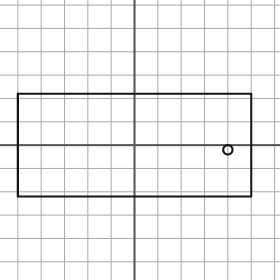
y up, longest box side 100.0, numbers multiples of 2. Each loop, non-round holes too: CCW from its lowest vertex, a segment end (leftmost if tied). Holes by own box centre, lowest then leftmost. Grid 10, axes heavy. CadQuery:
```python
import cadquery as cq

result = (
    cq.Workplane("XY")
    .moveTo(-50.0, -22.0)
    .lineTo(50.0, -22.0)
    .lineTo(50.0, 22.0)
    .lineTo(-50.0, 22.0)
    .close()
    .moveTo(40.0, -2.0)
    .circle(2.0)
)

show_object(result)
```